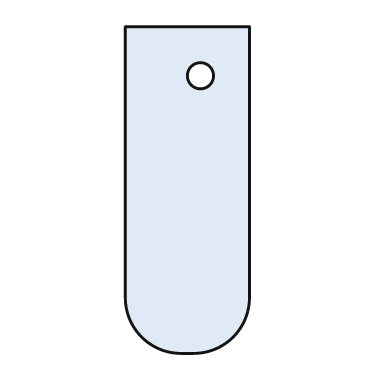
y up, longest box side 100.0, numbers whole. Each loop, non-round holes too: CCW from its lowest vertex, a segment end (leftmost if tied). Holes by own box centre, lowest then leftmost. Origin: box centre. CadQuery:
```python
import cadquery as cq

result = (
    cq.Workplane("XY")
    .moveTo(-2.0, -50.0)
    .lineTo(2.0, -50.0)
    .threePointArc((14.0, -45.0), (19.0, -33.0))
    .lineTo(19.0, 50.0)
    .lineTo(-19.0, 50.0)
    .lineTo(-19.0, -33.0)
    .threePointArc((-14.0, -45.0), (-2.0, -50.0))
    .close()
    .moveTo(4.0, 35.0)
    .circle(4.0)
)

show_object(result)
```